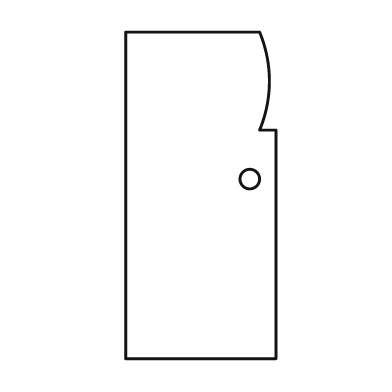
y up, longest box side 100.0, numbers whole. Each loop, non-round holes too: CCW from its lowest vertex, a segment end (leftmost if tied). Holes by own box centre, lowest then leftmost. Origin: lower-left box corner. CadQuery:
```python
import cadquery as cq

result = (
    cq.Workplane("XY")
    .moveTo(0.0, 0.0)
    .lineTo(46.0, 0.0)
    .lineTo(46.0, 70.0)
    .lineTo(41.0, 70.0)
    .threePointArc((44.0, 85.0), (41.0, 100.0))
    .lineTo(0.0, 100.0)
    .close()
    .moveTo(38.0, 55.0)
    .circle(3.0)
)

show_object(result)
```